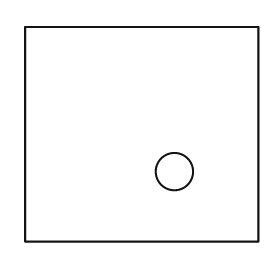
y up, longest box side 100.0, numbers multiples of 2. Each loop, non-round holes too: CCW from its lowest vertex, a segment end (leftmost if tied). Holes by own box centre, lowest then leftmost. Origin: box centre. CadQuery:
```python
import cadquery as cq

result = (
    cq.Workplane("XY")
    .moveTo(-50.0, -46.0)
    .lineTo(50.0, -46.0)
    .lineTo(50.0, 46.0)
    .lineTo(-50.0, 46.0)
    .close()
    .moveTo(14.0, -16.0)
    .circle(8.0)
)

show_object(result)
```